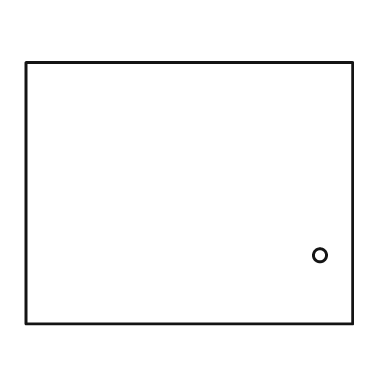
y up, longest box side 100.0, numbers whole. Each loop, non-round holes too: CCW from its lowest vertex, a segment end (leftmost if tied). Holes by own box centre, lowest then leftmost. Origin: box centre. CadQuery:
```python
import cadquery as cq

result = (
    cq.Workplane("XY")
    .moveTo(-50.0, -40.0)
    .lineTo(50.0, -40.0)
    .lineTo(50.0, 40.0)
    .lineTo(-50.0, 40.0)
    .close()
    .moveTo(40.0, -19.0)
    .circle(2.0)
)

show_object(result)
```